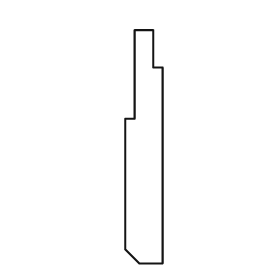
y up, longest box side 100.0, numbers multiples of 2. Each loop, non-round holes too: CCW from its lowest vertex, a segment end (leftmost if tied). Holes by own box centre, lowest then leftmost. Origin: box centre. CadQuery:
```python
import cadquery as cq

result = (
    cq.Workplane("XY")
    .moveTo(-2.0, -50.0)
    .lineTo(8.0, -50.0)
    .lineTo(8.0, 34.0)
    .lineTo(4.0, 34.0)
    .lineTo(4.0, 50.0)
    .lineTo(-4.0, 50.0)
    .lineTo(-4.0, 12.0)
    .lineTo(-8.0, 12.0)
    .lineTo(-8.0, -44.0)
    .close()
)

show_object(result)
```